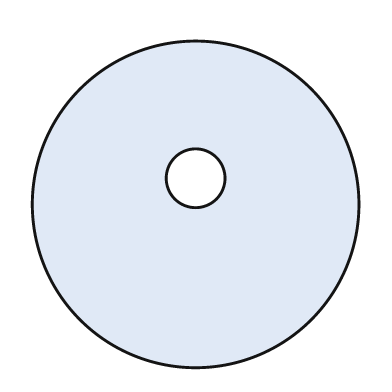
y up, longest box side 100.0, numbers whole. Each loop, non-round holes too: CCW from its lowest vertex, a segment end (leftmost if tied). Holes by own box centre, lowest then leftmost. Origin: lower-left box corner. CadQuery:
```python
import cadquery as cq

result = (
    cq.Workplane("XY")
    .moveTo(50.0, 50.0)
    .circle(50.0)
    .moveTo(50.0, 58.0)
    .circle(9.0)
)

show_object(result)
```